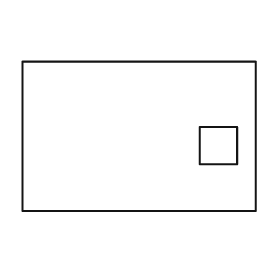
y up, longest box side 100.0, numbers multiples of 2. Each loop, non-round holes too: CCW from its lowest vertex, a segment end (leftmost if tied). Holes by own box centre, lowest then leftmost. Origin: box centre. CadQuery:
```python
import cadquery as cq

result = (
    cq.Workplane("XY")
    .moveTo(-50.0, -32.0)
    .lineTo(50.0, -32.0)
    .lineTo(50.0, 32.0)
    .lineTo(-50.0, 32.0)
    .close()
    .moveTo(26.0, -12.0)
    .lineTo(42.0, -12.0)
    .lineTo(42.0, 4.0)
    .lineTo(26.0, 4.0)
    .close()
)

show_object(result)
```